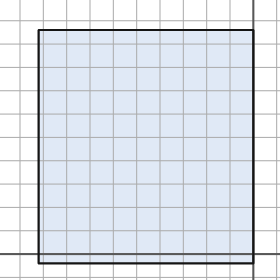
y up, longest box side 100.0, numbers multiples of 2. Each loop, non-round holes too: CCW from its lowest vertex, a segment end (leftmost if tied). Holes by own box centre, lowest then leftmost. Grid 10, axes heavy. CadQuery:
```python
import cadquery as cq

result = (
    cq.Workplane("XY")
    .moveTo(-92.0, -4.0)
    .lineTo(0.0, -4.0)
    .lineTo(0.0, 96.0)
    .lineTo(-92.0, 96.0)
    .close()
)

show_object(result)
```